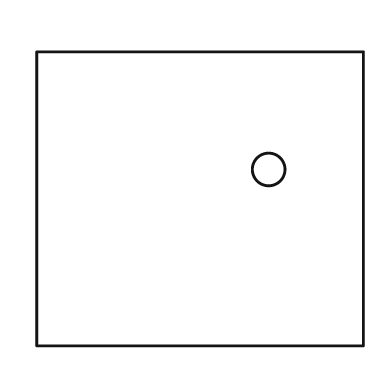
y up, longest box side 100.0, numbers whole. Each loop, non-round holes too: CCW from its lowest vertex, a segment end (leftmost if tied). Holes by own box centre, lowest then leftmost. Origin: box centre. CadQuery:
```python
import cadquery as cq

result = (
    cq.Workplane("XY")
    .moveTo(-50.0, -45.0)
    .lineTo(50.0, -45.0)
    .lineTo(50.0, 45.0)
    .lineTo(-50.0, 45.0)
    .close()
    .moveTo(21.0, 9.0)
    .circle(5.0)
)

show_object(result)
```